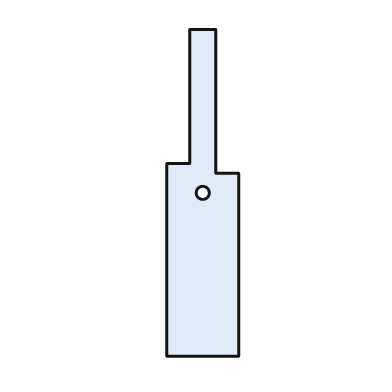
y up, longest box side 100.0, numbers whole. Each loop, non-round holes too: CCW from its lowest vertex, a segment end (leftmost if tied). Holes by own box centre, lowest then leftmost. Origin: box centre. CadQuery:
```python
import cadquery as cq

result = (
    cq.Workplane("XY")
    .moveTo(-11.0, -50.0)
    .lineTo(11.0, -50.0)
    .lineTo(11.0, 6.0)
    .lineTo(4.0, 6.0)
    .lineTo(4.0, 50.0)
    .lineTo(-4.0, 50.0)
    .lineTo(-4.0, 9.0)
    .lineTo(-11.0, 9.0)
    .close()
    .moveTo(0.0, 0.0)
    .circle(2.0)
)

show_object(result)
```